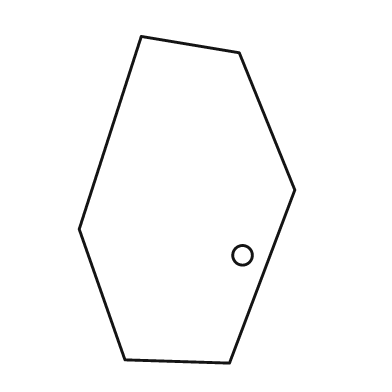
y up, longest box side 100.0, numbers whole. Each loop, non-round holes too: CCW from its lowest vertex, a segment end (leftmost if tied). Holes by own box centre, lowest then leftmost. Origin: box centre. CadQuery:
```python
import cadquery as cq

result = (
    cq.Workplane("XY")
    .moveTo(13.0, -50.0)
    .lineTo(33.0, 3.0)
    .lineTo(16.0, 45.0)
    .lineTo(-14.0, 50.0)
    .lineTo(-33.0, -9.0)
    .lineTo(-19.0, -49.0)
    .close()
    .moveTo(17.0, -17.0)
    .circle(3.0)
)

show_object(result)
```